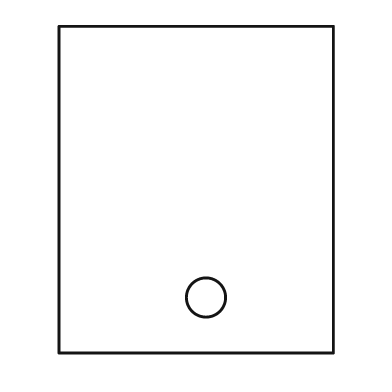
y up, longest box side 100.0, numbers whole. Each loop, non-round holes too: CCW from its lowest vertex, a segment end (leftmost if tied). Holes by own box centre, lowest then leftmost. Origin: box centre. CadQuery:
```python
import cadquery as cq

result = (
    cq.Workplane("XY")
    .moveTo(-42.0, -50.0)
    .lineTo(42.0, -50.0)
    .lineTo(42.0, 50.0)
    .lineTo(-42.0, 50.0)
    .close()
    .moveTo(3.0, -33.0)
    .circle(6.0)
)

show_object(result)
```